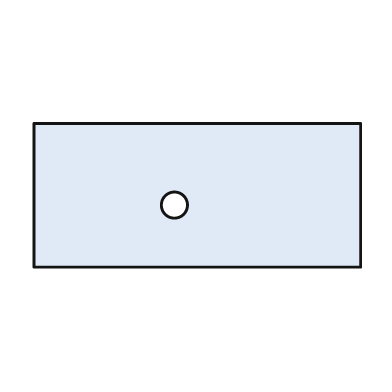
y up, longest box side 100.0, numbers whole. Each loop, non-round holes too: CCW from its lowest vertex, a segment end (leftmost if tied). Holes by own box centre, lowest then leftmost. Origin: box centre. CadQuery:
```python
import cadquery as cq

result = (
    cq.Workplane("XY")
    .moveTo(-50.0, -22.0)
    .lineTo(50.0, -22.0)
    .lineTo(50.0, 22.0)
    .lineTo(-50.0, 22.0)
    .close()
    .moveTo(-7.0, -3.0)
    .circle(4.0)
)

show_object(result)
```